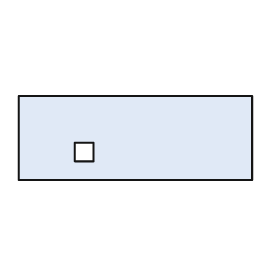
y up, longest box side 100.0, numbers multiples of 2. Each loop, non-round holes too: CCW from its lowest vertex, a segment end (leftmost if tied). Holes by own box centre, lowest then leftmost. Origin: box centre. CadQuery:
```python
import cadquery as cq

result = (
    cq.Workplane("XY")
    .moveTo(-50.0, -18.0)
    .lineTo(50.0, -18.0)
    .lineTo(50.0, 18.0)
    .lineTo(-50.0, 18.0)
    .close()
    .moveTo(-26.0, -10.0)
    .lineTo(-18.0, -10.0)
    .lineTo(-18.0, -2.0)
    .lineTo(-26.0, -2.0)
    .close()
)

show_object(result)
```